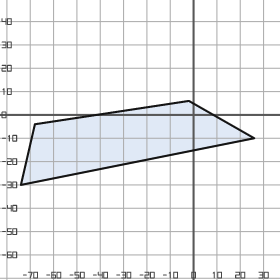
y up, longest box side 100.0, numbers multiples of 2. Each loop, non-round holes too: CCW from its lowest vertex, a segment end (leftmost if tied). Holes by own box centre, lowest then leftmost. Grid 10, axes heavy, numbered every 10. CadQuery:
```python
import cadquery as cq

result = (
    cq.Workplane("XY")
    .moveTo(-74.0, -30.0)
    .lineTo(26.0, -10.0)
    .lineTo(-2.0, 6.0)
    .lineTo(-68.0, -4.0)
    .close()
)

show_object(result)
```